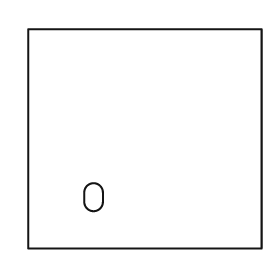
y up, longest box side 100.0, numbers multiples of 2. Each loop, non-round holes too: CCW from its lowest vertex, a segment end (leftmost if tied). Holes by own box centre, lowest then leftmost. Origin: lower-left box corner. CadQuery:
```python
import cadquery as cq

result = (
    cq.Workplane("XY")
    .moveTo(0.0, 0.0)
    .lineTo(100.0, 0.0)
    .lineTo(100.0, 94.0)
    .lineTo(0.0, 94.0)
    .close()
    .moveTo(24.0, 20.0)
    .threePointArc((28.0, 16.0), (32.0, 20.0))
    .lineTo(32.0, 24.0)
    .threePointArc((28.0, 28.0), (24.0, 24.0))
    .close()
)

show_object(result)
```